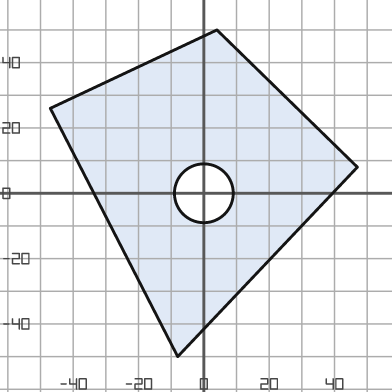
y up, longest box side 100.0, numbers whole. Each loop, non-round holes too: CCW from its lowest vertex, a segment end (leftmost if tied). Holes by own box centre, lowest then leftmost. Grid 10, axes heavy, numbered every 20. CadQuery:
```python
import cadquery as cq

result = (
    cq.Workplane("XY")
    .moveTo(-8.0, -50.0)
    .lineTo(47.0, 8.0)
    .lineTo(4.0, 50.0)
    .lineTo(-47.0, 26.0)
    .close()
    .moveTo(0.0, 0.0)
    .circle(9.0)
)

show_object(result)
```